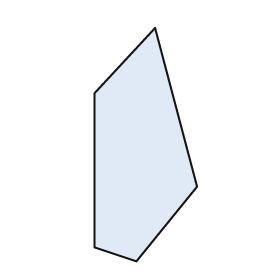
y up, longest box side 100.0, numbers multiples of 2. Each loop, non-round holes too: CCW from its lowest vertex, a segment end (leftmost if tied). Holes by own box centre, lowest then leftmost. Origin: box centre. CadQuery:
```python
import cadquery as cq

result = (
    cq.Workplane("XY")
    .moveTo(-4.0, -50.0)
    .lineTo(22.0, -18.0)
    .lineTo(4.0, 50.0)
    .lineTo(-22.0, 22.0)
    .lineTo(-22.0, -44.0)
    .close()
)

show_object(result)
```